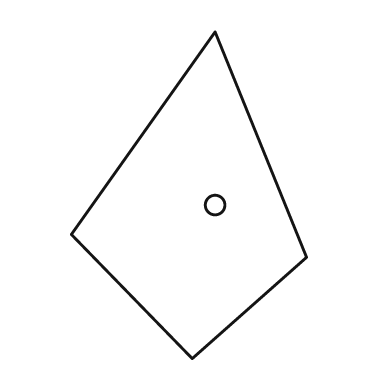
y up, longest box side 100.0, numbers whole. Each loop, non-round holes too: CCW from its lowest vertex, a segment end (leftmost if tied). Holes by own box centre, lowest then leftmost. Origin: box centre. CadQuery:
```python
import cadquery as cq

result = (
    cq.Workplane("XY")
    .moveTo(1.0, -50.0)
    .lineTo(36.0, -19.0)
    .lineTo(8.0, 50.0)
    .lineTo(-36.0, -12.0)
    .close()
    .moveTo(8.0, -3.0)
    .circle(3.0)
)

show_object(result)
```